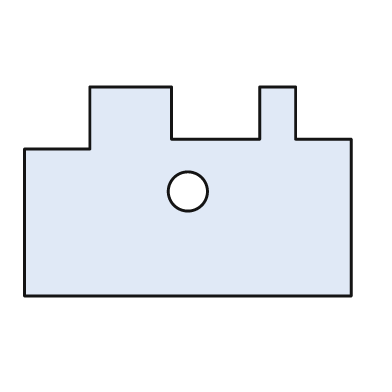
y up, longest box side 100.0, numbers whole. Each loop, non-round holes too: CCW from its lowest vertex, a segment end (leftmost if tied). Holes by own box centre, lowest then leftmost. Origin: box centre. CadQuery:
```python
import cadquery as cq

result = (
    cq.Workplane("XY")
    .moveTo(-50.0, -32.0)
    .lineTo(50.0, -32.0)
    .lineTo(50.0, 16.0)
    .lineTo(33.0, 16.0)
    .lineTo(33.0, 32.0)
    .lineTo(22.0, 32.0)
    .lineTo(22.0, 16.0)
    .lineTo(-5.0, 16.0)
    .lineTo(-5.0, 32.0)
    .lineTo(-30.0, 32.0)
    .lineTo(-30.0, 13.0)
    .lineTo(-50.0, 13.0)
    .close()
    .moveTo(0.0, 0.0)
    .circle(6.0)
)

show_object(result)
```